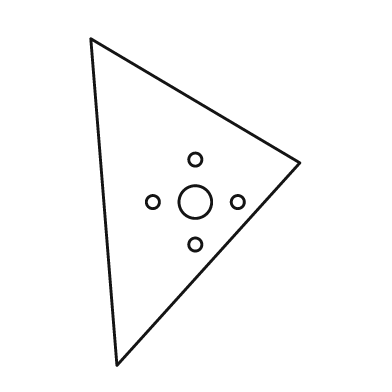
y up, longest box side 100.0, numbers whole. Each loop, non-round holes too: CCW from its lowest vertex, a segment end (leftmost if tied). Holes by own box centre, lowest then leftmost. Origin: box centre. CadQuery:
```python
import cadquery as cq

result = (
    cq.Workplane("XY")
    .moveTo(-24.0, -50.0)
    .lineTo(32.0, 12.0)
    .lineTo(-32.0, 50.0)
    .close()
    .moveTo(0.0, -13.0)
    .circle(2.0)
    .moveTo(-13.0, 0.0)
    .circle(2.0)
    .moveTo(0.0, 0.0)
    .circle(5.0)
    .moveTo(13.0, 0.0)
    .circle(2.0)
    .moveTo(0.0, 13.0)
    .circle(2.0)
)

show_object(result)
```